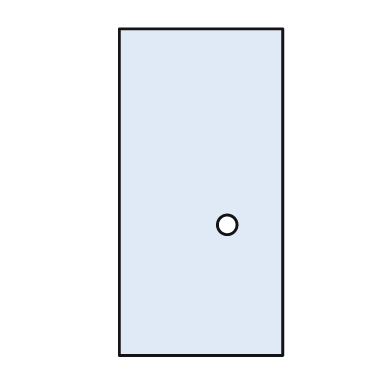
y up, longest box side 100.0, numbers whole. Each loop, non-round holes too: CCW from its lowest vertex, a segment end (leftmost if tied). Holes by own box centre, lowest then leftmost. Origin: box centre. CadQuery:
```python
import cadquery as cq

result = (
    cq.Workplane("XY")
    .moveTo(-25.0, -50.0)
    .lineTo(25.0, -50.0)
    .lineTo(25.0, 50.0)
    .lineTo(-25.0, 50.0)
    .close()
    .moveTo(8.0, -10.0)
    .circle(3.0)
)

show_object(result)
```